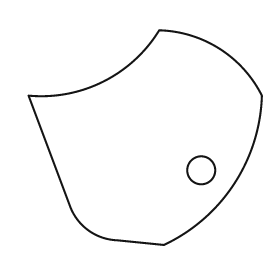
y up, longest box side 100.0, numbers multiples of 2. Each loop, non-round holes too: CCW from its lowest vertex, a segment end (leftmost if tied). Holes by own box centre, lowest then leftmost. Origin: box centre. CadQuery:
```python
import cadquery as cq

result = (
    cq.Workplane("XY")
    .moveTo(8.0, -46.0)
    .threePointArc((38.0, -20.0), (50.0, 18.0))
    .threePointArc((32.0, 38.0), (6.0, 46.0))
    .threePointArc((-18.0, 24.0), (-50.0, 18.0))
    .lineTo(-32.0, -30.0)
    .threePointArc((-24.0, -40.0), (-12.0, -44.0))
    .close()
    .moveTo(24.0, -14.0)
    .circle(6.0)
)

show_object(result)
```